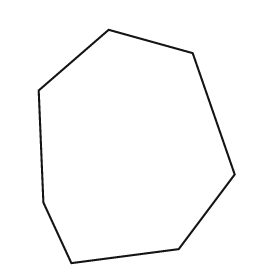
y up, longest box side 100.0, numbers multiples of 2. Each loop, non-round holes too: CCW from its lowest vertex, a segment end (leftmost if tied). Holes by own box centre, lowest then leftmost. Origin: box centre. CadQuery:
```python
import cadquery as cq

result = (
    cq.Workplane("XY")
    .moveTo(-28.0, -50.0)
    .lineTo(18.0, -44.0)
    .lineTo(42.0, -12.0)
    .lineTo(24.0, 40.0)
    .lineTo(-12.0, 50.0)
    .lineTo(-42.0, 24.0)
    .lineTo(-40.0, -24.0)
    .close()
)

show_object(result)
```